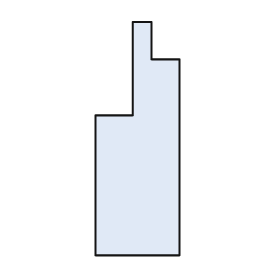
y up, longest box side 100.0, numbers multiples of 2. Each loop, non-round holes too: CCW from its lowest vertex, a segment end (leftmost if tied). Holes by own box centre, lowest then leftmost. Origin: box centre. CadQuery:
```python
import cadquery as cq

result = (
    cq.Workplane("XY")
    .moveTo(-18.0, -50.0)
    .lineTo(18.0, -50.0)
    .lineTo(18.0, 34.0)
    .lineTo(6.0, 34.0)
    .lineTo(6.0, 50.0)
    .lineTo(-2.0, 50.0)
    .lineTo(-2.0, 10.0)
    .lineTo(-18.0, 10.0)
    .close()
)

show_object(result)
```